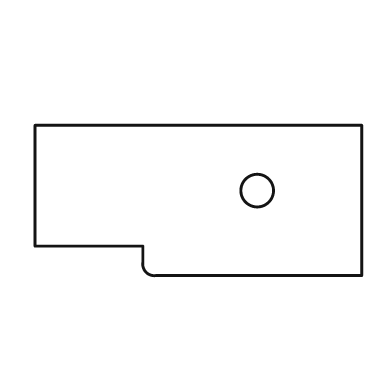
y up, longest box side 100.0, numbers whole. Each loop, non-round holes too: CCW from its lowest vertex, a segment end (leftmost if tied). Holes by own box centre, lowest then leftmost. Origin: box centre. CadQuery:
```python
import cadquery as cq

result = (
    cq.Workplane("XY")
    .moveTo(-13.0, -23.0)
    .lineTo(50.0, -23.0)
    .lineTo(50.0, 23.0)
    .lineTo(-50.0, 23.0)
    .lineTo(-50.0, -14.0)
    .lineTo(-17.0, -14.0)
    .lineTo(-17.0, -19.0)
    .threePointArc((-16.0, -22.0), (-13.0, -23.0))
    .close()
    .moveTo(18.0, 3.0)
    .circle(5.0)
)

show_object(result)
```